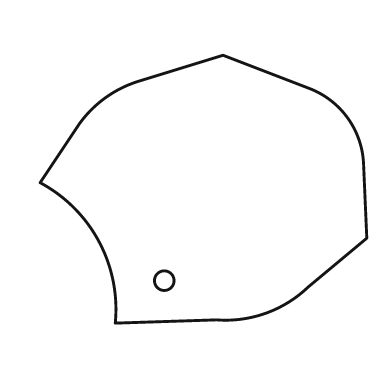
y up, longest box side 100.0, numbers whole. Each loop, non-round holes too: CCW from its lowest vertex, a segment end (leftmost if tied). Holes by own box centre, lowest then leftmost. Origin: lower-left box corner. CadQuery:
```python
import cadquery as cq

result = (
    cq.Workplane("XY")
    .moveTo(23.0, 0.0)
    .lineTo(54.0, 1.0)
    .threePointArc((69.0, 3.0), (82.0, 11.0))
    .lineTo(100.0, 26.0)
    .lineTo(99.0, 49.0)
    .threePointArc((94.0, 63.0), (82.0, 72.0))
    .lineTo(56.0, 82.0)
    .lineTo(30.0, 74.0)
    .threePointArc((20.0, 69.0), (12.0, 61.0))
    .lineTo(0.0, 43.0)
    .threePointArc((18.0, 25.0), (23.0, 0.0))
    .close()
    .moveTo(38.0, 13.0)
    .circle(3.0)
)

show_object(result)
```